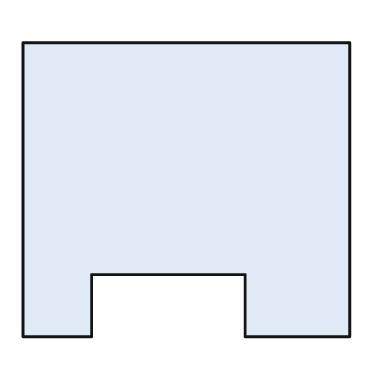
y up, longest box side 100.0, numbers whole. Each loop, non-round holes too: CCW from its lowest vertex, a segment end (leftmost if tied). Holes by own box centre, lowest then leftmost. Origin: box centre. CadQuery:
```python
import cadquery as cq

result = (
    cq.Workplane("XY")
    .moveTo(-50.0, -45.0)
    .lineTo(-29.0, -45.0)
    .lineTo(-29.0, -26.0)
    .lineTo(18.0, -26.0)
    .lineTo(18.0, -45.0)
    .lineTo(50.0, -45.0)
    .lineTo(50.0, 45.0)
    .lineTo(-50.0, 45.0)
    .close()
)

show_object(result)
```